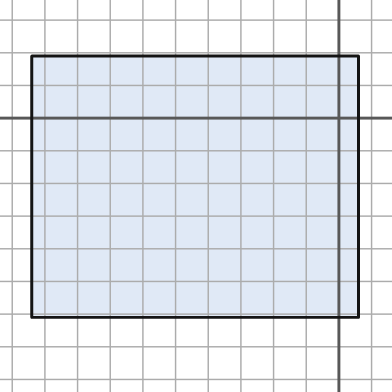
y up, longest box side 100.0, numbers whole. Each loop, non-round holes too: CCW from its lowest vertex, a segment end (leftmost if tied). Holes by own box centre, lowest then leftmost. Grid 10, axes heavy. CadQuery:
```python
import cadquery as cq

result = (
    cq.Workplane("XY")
    .moveTo(-94.0, -61.0)
    .lineTo(6.0, -61.0)
    .lineTo(6.0, 19.0)
    .lineTo(-94.0, 19.0)
    .close()
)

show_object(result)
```